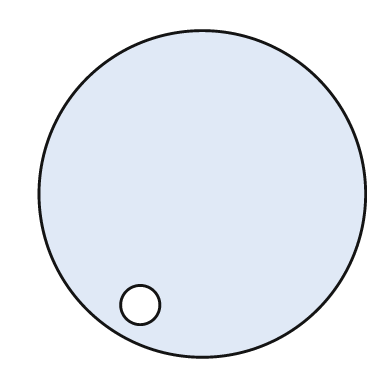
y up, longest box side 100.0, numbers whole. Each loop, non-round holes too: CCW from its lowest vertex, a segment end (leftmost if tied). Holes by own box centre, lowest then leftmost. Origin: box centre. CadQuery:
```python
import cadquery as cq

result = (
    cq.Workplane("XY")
    .moveTo(0.0, 0.0)
    .circle(50.0)
    .moveTo(-19.0, -34.0)
    .circle(6.0)
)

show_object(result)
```